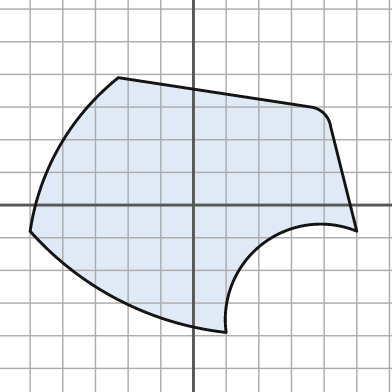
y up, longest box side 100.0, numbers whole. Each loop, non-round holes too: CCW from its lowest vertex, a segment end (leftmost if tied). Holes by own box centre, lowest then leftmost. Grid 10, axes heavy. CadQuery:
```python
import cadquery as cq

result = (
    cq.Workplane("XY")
    .moveTo(10.0, -39.0)
    .threePointArc((21.0, -12.0), (50.0, -8.0))
    .lineTo(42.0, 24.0)
    .threePointArc((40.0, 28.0), (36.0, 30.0))
    .lineTo(-23.0, 39.0)
    .threePointArc((-41.0, 18.0), (-50.0, -8.0))
    .threePointArc((-23.0, -29.0), (10.0, -39.0))
    .close()
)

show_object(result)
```